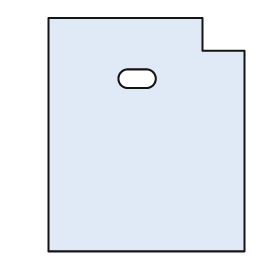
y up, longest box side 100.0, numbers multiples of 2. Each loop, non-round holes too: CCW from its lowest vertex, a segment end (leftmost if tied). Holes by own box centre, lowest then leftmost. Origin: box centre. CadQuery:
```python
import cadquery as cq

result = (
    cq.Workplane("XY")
    .moveTo(-42.0, -50.0)
    .lineTo(42.0, -50.0)
    .lineTo(42.0, 36.0)
    .lineTo(24.0, 36.0)
    .lineTo(24.0, 50.0)
    .lineTo(-42.0, 50.0)
    .close()
    .moveTo(-8.0, 20.0)
    .lineTo(0.0, 20.0)
    .threePointArc((4.0, 24.0), (0.0, 28.0))
    .lineTo(-8.0, 28.0)
    .threePointArc((-12.0, 24.0), (-8.0, 20.0))
    .close()
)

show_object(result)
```